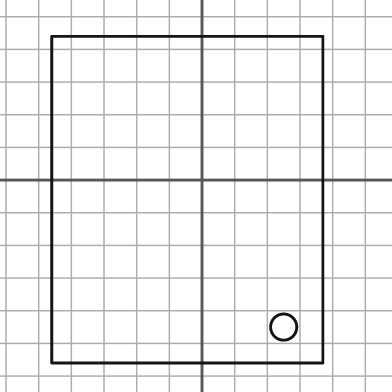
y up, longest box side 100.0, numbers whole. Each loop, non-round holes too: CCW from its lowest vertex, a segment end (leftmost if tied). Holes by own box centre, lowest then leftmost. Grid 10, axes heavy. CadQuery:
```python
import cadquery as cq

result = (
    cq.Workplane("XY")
    .moveTo(-46.0, -56.0)
    .lineTo(37.0, -56.0)
    .lineTo(37.0, 44.0)
    .lineTo(-46.0, 44.0)
    .close()
    .moveTo(25.0, -45.0)
    .circle(4.0)
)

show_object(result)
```